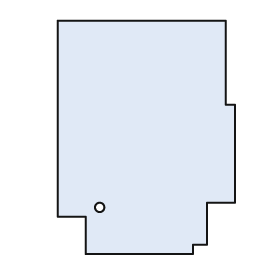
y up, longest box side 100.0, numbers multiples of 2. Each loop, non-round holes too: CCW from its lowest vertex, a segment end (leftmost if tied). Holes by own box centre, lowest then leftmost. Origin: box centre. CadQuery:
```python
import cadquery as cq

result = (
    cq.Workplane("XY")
    .moveTo(-26.0, -50.0)
    .lineTo(20.0, -50.0)
    .lineTo(20.0, -46.0)
    .lineTo(26.0, -46.0)
    .lineTo(26.0, -28.0)
    .lineTo(38.0, -28.0)
    .lineTo(38.0, 14.0)
    .lineTo(34.0, 14.0)
    .lineTo(34.0, 50.0)
    .lineTo(-38.0, 50.0)
    .lineTo(-38.0, -34.0)
    .lineTo(-26.0, -34.0)
    .close()
    .moveTo(-20.0, -30.0)
    .circle(2.0)
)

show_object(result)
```